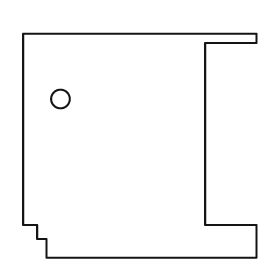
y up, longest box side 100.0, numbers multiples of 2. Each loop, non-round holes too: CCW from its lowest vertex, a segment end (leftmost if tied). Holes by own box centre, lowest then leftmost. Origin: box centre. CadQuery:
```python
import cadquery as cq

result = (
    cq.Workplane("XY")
    .moveTo(-40.0, -48.0)
    .lineTo(50.0, -48.0)
    .lineTo(50.0, -34.0)
    .lineTo(28.0, -34.0)
    .lineTo(28.0, 44.0)
    .lineTo(50.0, 44.0)
    .lineTo(50.0, 48.0)
    .lineTo(-50.0, 48.0)
    .lineTo(-50.0, -34.0)
    .lineTo(-44.0, -34.0)
    .lineTo(-44.0, -40.0)
    .lineTo(-40.0, -40.0)
    .close()
    .moveTo(-34.0, 20.0)
    .circle(4.0)
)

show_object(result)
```